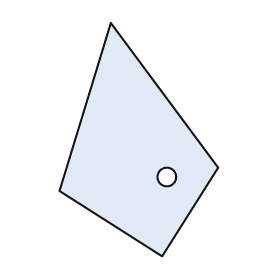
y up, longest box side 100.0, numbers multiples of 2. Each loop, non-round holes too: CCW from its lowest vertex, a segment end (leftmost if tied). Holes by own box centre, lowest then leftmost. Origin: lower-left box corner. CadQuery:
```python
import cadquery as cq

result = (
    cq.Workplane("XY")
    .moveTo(44.0, 0.0)
    .lineTo(68.0, 38.0)
    .lineTo(22.0, 100.0)
    .lineTo(0.0, 28.0)
    .close()
    .moveTo(46.0, 34.0)
    .circle(4.0)
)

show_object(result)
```